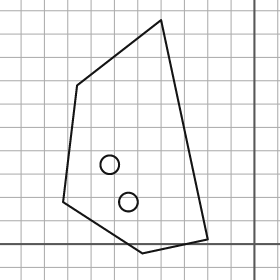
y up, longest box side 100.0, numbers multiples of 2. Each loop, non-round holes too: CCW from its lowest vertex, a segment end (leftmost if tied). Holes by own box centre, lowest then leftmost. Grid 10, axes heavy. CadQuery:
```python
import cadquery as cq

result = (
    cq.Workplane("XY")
    .moveTo(-48.0, -4.0)
    .lineTo(-20.0, 2.0)
    .lineTo(-40.0, 96.0)
    .lineTo(-76.0, 68.0)
    .lineTo(-82.0, 18.0)
    .close()
    .moveTo(-54.0, 18.0)
    .circle(4.0)
    .moveTo(-62.0, 34.0)
    .circle(4.0)
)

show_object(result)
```